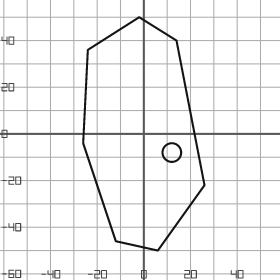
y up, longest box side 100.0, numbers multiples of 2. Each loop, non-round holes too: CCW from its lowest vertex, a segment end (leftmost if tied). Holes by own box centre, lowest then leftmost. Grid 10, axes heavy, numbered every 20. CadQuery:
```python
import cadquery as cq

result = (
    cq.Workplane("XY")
    .moveTo(6.0, -50.0)
    .lineTo(26.0, -22.0)
    .lineTo(14.0, 40.0)
    .lineTo(-2.0, 50.0)
    .lineTo(-24.0, 36.0)
    .lineTo(-26.0, -4.0)
    .lineTo(-12.0, -46.0)
    .close()
    .moveTo(12.0, -8.0)
    .circle(4.0)
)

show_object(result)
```